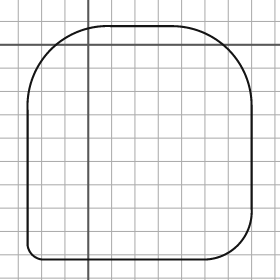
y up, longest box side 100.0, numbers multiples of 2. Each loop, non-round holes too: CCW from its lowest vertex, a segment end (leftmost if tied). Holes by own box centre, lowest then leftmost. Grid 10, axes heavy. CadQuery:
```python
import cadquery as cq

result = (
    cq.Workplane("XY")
    .moveTo(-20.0, -92.0)
    .lineTo(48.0, -92.0)
    .threePointArc((64.0, -86.0), (70.0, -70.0))
    .lineTo(70.0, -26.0)
    .threePointArc((60.0, -2.0), (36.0, 8.0))
    .lineTo(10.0, 8.0)
    .threePointArc((-16.0, -2.0), (-26.0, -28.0))
    .lineTo(-26.0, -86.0)
    .threePointArc((-24.0, -90.0), (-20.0, -92.0))
    .close()
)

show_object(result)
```